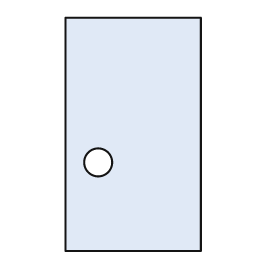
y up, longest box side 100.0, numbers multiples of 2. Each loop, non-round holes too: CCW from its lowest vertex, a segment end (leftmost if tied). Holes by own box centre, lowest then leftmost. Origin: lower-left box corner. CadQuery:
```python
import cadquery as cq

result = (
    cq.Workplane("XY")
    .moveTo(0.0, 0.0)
    .lineTo(58.0, 0.0)
    .lineTo(58.0, 100.0)
    .lineTo(0.0, 100.0)
    .close()
    .moveTo(14.0, 38.0)
    .circle(6.0)
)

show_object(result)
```